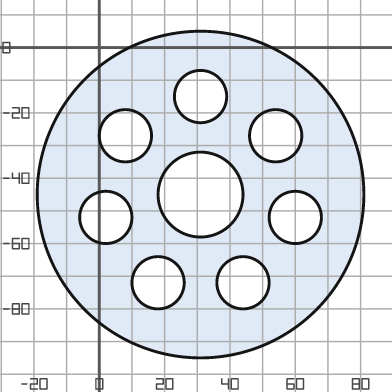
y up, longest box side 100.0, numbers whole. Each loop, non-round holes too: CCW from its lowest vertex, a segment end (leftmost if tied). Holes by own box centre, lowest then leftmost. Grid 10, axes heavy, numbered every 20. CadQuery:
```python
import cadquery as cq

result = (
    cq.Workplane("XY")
    .moveTo(31.0, -45.0)
    .circle(50.0)
    .moveTo(18.0, -72.0)
    .circle(8.0)
    .moveTo(44.0, -72.0)
    .circle(8.0)
    .moveTo(2.0, -52.0)
    .circle(8.0)
    .moveTo(60.0, -52.0)
    .circle(8.0)
    .moveTo(31.0, -45.0)
    .circle(13.0)
    .moveTo(8.0, -27.0)
    .circle(8.0)
    .moveTo(54.0, -27.0)
    .circle(8.0)
    .moveTo(31.0, -15.0)
    .circle(8.0)
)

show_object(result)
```